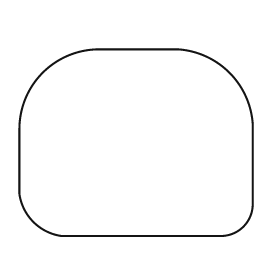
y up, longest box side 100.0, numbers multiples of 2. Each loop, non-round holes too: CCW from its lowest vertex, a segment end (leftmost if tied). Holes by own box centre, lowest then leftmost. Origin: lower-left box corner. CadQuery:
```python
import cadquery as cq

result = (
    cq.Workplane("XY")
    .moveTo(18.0, 0.0)
    .lineTo(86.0, 0.0)
    .threePointArc((96.0, 4.0), (100.0, 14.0))
    .lineTo(100.0, 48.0)
    .threePointArc((90.0, 70.0), (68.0, 80.0))
    .lineTo(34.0, 80.0)
    .threePointArc((10.0, 70.0), (0.0, 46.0))
    .lineTo(0.0, 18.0)
    .threePointArc((6.0, 6.0), (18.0, 0.0))
    .close()
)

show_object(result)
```